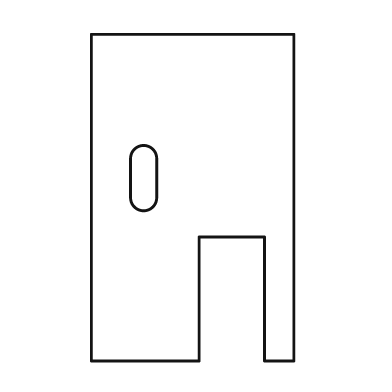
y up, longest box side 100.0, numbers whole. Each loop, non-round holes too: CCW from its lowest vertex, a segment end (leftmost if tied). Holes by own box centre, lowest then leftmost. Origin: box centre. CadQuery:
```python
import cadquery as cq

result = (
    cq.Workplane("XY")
    .moveTo(-31.0, -50.0)
    .lineTo(2.0, -50.0)
    .lineTo(2.0, -12.0)
    .lineTo(22.0, -12.0)
    .lineTo(22.0, -50.0)
    .lineTo(31.0, -50.0)
    .lineTo(31.0, 50.0)
    .lineTo(-31.0, 50.0)
    .close()
    .moveTo(-19.0, 0.0)
    .threePointArc((-15.0, -4.0), (-11.0, 0.0))
    .lineTo(-11.0, 12.0)
    .threePointArc((-15.0, 16.0), (-19.0, 12.0))
    .close()
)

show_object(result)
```